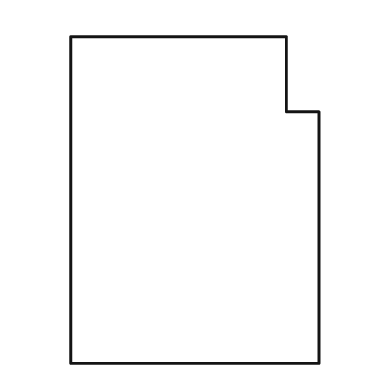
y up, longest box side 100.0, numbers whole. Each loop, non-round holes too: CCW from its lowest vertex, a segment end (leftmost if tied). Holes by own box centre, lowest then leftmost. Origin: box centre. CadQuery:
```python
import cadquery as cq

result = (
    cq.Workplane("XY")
    .moveTo(-38.0, -50.0)
    .lineTo(38.0, -50.0)
    .lineTo(38.0, 27.0)
    .lineTo(28.0, 27.0)
    .lineTo(28.0, 50.0)
    .lineTo(-38.0, 50.0)
    .close()
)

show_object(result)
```